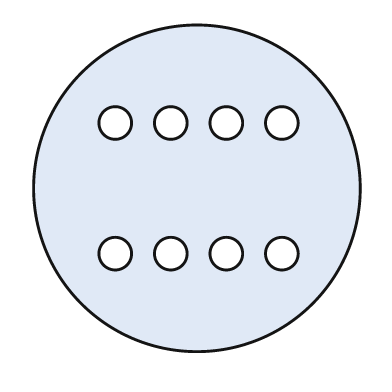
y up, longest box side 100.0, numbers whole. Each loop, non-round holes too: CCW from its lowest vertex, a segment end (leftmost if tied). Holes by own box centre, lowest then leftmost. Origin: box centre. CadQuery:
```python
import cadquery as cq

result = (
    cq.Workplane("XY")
    .moveTo(0.0, 0.0)
    .circle(50.0)
    .moveTo(-25.0, -20.0)
    .circle(5.0)
    .moveTo(-8.0, -20.0)
    .circle(5.0)
    .moveTo(9.0, -20.0)
    .circle(5.0)
    .moveTo(26.0, -20.0)
    .circle(5.0)
    .moveTo(-25.0, 20.0)
    .circle(5.0)
    .moveTo(-8.0, 20.0)
    .circle(5.0)
    .moveTo(9.0, 20.0)
    .circle(5.0)
    .moveTo(26.0, 20.0)
    .circle(5.0)
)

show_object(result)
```